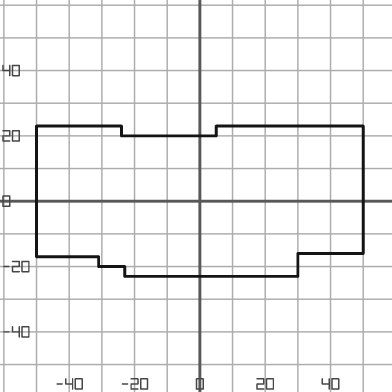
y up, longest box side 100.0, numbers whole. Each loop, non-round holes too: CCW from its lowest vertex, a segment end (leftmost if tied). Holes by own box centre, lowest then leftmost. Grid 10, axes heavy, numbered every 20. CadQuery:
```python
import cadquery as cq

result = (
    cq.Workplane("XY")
    .moveTo(-23.0, -23.0)
    .lineTo(30.0, -23.0)
    .lineTo(30.0, -16.0)
    .lineTo(50.0, -16.0)
    .lineTo(50.0, 23.0)
    .lineTo(5.0, 23.0)
    .lineTo(5.0, 20.0)
    .lineTo(-24.0, 20.0)
    .lineTo(-24.0, 23.0)
    .lineTo(-50.0, 23.0)
    .lineTo(-50.0, -17.0)
    .lineTo(-31.0, -17.0)
    .lineTo(-31.0, -20.0)
    .lineTo(-23.0, -20.0)
    .close()
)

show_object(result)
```